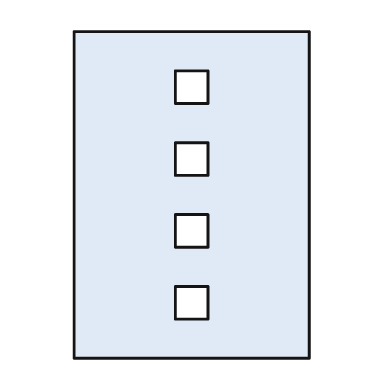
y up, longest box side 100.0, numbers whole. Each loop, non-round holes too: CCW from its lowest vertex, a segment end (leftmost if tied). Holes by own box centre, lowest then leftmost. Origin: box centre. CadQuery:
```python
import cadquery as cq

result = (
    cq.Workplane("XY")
    .moveTo(-36.0, -50.0)
    .lineTo(36.0, -50.0)
    .lineTo(36.0, 50.0)
    .lineTo(-36.0, 50.0)
    .close()
    .moveTo(-5.0, -38.0)
    .lineTo(5.0, -38.0)
    .lineTo(5.0, -28.0)
    .lineTo(-5.0, -28.0)
    .close()
    .moveTo(-5.0, -16.0)
    .lineTo(5.0, -16.0)
    .lineTo(5.0, -6.0)
    .lineTo(-5.0, -6.0)
    .close()
    .moveTo(-5.0, 6.0)
    .lineTo(5.0, 6.0)
    .lineTo(5.0, 16.0)
    .lineTo(-5.0, 16.0)
    .close()
    .moveTo(-5.0, 28.0)
    .lineTo(5.0, 28.0)
    .lineTo(5.0, 38.0)
    .lineTo(-5.0, 38.0)
    .close()
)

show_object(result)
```